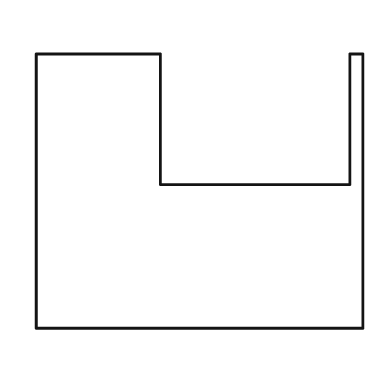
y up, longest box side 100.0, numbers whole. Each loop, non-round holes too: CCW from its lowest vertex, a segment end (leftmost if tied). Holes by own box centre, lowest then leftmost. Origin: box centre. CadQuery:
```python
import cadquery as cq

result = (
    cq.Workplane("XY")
    .moveTo(-50.0, -42.0)
    .lineTo(50.0, -42.0)
    .lineTo(50.0, 42.0)
    .lineTo(46.0, 42.0)
    .lineTo(46.0, 2.0)
    .lineTo(-12.0, 2.0)
    .lineTo(-12.0, 42.0)
    .lineTo(-50.0, 42.0)
    .close()
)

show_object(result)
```